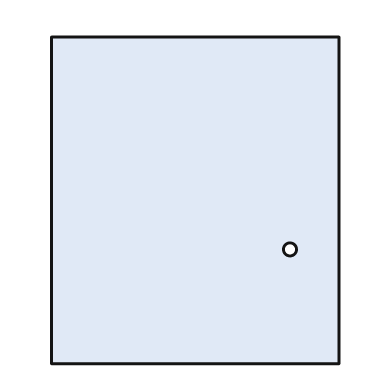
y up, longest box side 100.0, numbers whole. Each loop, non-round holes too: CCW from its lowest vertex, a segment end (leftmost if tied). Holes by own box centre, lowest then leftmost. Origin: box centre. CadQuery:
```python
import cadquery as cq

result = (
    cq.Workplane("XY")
    .moveTo(-44.0, -50.0)
    .lineTo(44.0, -50.0)
    .lineTo(44.0, 50.0)
    .lineTo(-44.0, 50.0)
    .close()
    .moveTo(29.0, -15.0)
    .circle(2.0)
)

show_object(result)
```